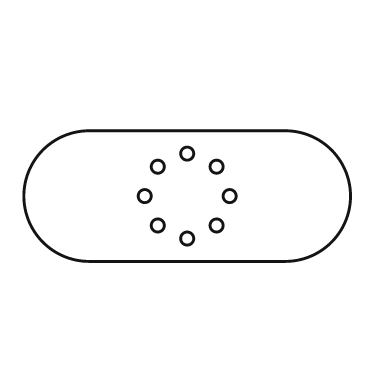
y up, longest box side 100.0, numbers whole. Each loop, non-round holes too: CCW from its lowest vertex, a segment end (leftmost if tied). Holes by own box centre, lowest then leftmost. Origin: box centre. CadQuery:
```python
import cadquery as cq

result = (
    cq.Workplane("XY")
    .moveTo(-30.0, -20.0)
    .lineTo(30.0, -20.0)
    .threePointArc((50.0, 0.0), (30.0, 20.0))
    .lineTo(-30.0, 20.0)
    .threePointArc((-50.0, 0.0), (-30.0, -20.0))
    .close()
    .moveTo(0.0, -13.0)
    .circle(2.0)
    .moveTo(-9.0, -9.0)
    .circle(2.0)
    .moveTo(9.0, -9.0)
    .circle(2.0)
    .moveTo(-13.0, 0.0)
    .circle(2.0)
    .moveTo(13.0, 0.0)
    .circle(2.0)
    .moveTo(-9.0, 9.0)
    .circle(2.0)
    .moveTo(9.0, 9.0)
    .circle(2.0)
    .moveTo(0.0, 13.0)
    .circle(2.0)
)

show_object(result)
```